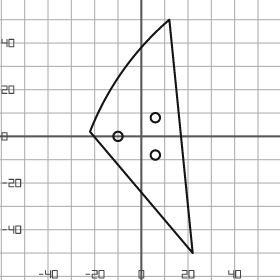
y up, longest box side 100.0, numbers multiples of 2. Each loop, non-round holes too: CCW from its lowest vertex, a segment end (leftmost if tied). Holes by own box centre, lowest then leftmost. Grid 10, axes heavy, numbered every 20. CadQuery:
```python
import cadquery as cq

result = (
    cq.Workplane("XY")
    .moveTo(22.0, -50.0)
    .lineTo(12.0, 50.0)
    .threePointArc((-8.0, 28.0), (-22.0, 2.0))
    .close()
    .moveTo(6.0, -8.0)
    .circle(2.0)
    .moveTo(-10.0, 0.0)
    .circle(2.0)
    .moveTo(6.0, 8.0)
    .circle(2.0)
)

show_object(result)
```